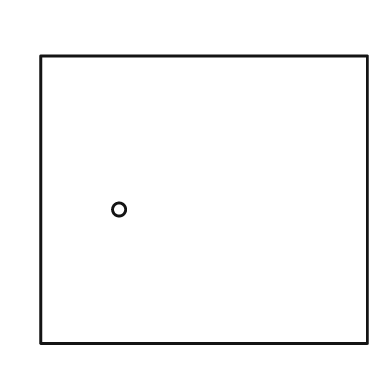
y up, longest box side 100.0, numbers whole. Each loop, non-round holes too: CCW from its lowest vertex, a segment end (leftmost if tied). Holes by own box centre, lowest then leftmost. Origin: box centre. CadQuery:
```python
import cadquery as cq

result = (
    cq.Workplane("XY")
    .moveTo(-50.0, -44.0)
    .lineTo(50.0, -44.0)
    .lineTo(50.0, 44.0)
    .lineTo(-50.0, 44.0)
    .close()
    .moveTo(-26.0, -3.0)
    .circle(2.0)
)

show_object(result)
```